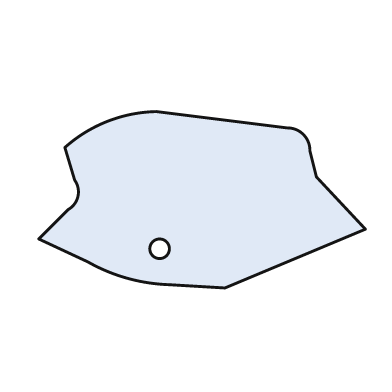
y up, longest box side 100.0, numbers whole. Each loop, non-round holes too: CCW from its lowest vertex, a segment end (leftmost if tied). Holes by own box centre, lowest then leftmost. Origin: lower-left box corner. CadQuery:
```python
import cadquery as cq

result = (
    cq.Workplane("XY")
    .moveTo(57.0, 0.0)
    .lineTo(100.0, 18.0)
    .lineTo(85.0, 34.0)
    .lineTo(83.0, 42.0)
    .threePointArc((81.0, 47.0), (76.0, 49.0))
    .lineTo(36.0, 54.0)
    .threePointArc((21.0, 51.0), (8.0, 43.0))
    .lineTo(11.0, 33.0)
    .threePointArc((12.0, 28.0), (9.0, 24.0))
    .lineTo(0.0, 15.0)
    .lineTo(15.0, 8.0)
    .threePointArc((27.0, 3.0), (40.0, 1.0))
    .close()
    .moveTo(37.0, 12.0)
    .circle(3.0)
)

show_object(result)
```